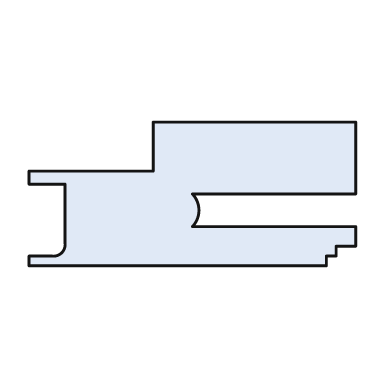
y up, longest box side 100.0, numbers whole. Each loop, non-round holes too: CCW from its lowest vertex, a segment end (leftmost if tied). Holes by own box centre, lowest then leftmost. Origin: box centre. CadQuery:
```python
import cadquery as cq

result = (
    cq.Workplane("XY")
    .moveTo(-50.0, -22.0)
    .lineTo(41.0, -22.0)
    .lineTo(41.0, -19.0)
    .lineTo(44.0, -19.0)
    .lineTo(44.0, -16.0)
    .lineTo(50.0, -16.0)
    .lineTo(50.0, -10.0)
    .lineTo(0.0, -10.0)
    .threePointArc((2.0, -5.0), (0.0, 0.0))
    .lineTo(50.0, 0.0)
    .lineTo(50.0, 22.0)
    .lineTo(-12.0, 22.0)
    .lineTo(-12.0, 7.0)
    .lineTo(-50.0, 7.0)
    .lineTo(-50.0, 3.0)
    .lineTo(-39.0, 3.0)
    .lineTo(-39.0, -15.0)
    .threePointArc((-40.0, -18.0), (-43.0, -19.0))
    .lineTo(-50.0, -19.0)
    .close()
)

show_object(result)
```